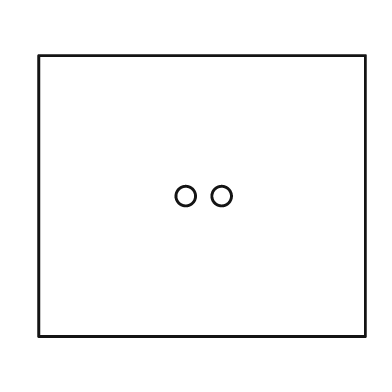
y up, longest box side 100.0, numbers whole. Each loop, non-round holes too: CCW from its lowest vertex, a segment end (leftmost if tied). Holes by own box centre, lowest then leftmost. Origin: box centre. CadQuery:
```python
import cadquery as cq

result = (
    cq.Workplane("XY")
    .moveTo(-50.0, -43.0)
    .lineTo(50.0, -43.0)
    .lineTo(50.0, 43.0)
    .lineTo(-50.0, 43.0)
    .close()
    .moveTo(-5.0, 0.0)
    .circle(3.0)
    .moveTo(6.0, 0.0)
    .circle(3.0)
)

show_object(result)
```